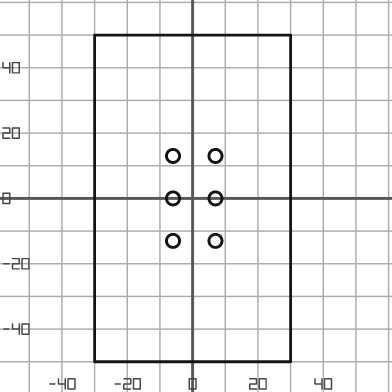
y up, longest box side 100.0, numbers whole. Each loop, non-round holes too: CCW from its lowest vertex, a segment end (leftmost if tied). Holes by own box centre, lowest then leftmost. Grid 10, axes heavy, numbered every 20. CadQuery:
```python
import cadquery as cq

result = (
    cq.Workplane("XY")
    .moveTo(-30.0, -50.0)
    .lineTo(30.0, -50.0)
    .lineTo(30.0, 50.0)
    .lineTo(-30.0, 50.0)
    .close()
    .moveTo(-6.0, -13.0)
    .circle(2.0)
    .moveTo(7.0, -13.0)
    .circle(2.0)
    .moveTo(-6.0, 0.0)
    .circle(2.0)
    .moveTo(7.0, 0.0)
    .circle(2.0)
    .moveTo(-6.0, 13.0)
    .circle(2.0)
    .moveTo(7.0, 13.0)
    .circle(2.0)
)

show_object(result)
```